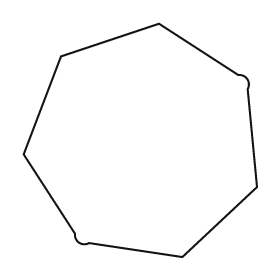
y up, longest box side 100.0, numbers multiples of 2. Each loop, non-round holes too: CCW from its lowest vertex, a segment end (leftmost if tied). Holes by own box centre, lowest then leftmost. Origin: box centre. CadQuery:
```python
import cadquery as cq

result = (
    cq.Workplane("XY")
    .moveTo(18.0, -50.0)
    .lineTo(50.0, -20.0)
    .lineTo(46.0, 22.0)
    .threePointArc((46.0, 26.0), (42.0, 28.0))
    .lineTo(8.0, 50.0)
    .lineTo(-34.0, 36.0)
    .lineTo(-50.0, -6.0)
    .lineTo(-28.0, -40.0)
    .threePointArc((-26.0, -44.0), (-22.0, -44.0))
    .close()
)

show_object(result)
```